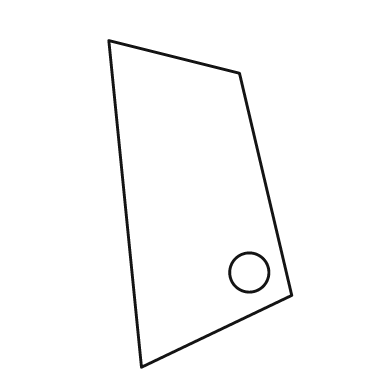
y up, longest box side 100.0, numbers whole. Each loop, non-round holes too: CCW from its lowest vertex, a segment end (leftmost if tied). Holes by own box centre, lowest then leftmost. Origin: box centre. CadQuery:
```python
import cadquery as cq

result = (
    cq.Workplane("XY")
    .moveTo(-18.0, -50.0)
    .lineTo(28.0, -28.0)
    .lineTo(12.0, 40.0)
    .lineTo(-28.0, 50.0)
    .close()
    .moveTo(15.0, -21.0)
    .circle(6.0)
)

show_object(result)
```